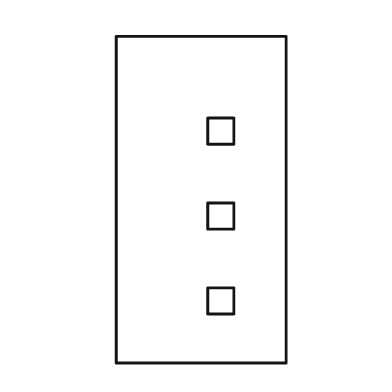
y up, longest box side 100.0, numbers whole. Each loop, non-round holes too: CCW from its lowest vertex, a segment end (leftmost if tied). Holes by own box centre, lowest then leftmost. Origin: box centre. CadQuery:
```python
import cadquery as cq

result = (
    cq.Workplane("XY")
    .moveTo(-26.0, -50.0)
    .lineTo(26.0, -50.0)
    .lineTo(26.0, 50.0)
    .lineTo(-26.0, 50.0)
    .close()
    .moveTo(2.0, -35.0)
    .lineTo(10.0, -35.0)
    .lineTo(10.0, -27.0)
    .lineTo(2.0, -27.0)
    .close()
    .moveTo(2.0, -9.0)
    .lineTo(10.0, -9.0)
    .lineTo(10.0, -1.0)
    .lineTo(2.0, -1.0)
    .close()
    .moveTo(2.0, 17.0)
    .lineTo(10.0, 17.0)
    .lineTo(10.0, 25.0)
    .lineTo(2.0, 25.0)
    .close()
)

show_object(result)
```